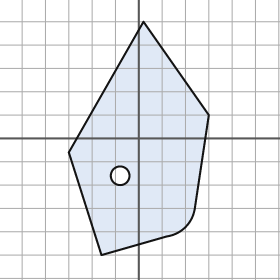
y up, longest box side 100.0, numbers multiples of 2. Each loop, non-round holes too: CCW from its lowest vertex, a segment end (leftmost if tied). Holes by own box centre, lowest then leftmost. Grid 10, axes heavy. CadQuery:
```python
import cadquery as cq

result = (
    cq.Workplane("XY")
    .moveTo(-16.0, -50.0)
    .lineTo(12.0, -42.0)
    .threePointArc((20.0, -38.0), (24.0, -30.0))
    .lineTo(30.0, 10.0)
    .lineTo(2.0, 50.0)
    .lineTo(-30.0, -6.0)
    .close()
    .moveTo(-8.0, -16.0)
    .circle(4.0)
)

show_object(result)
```